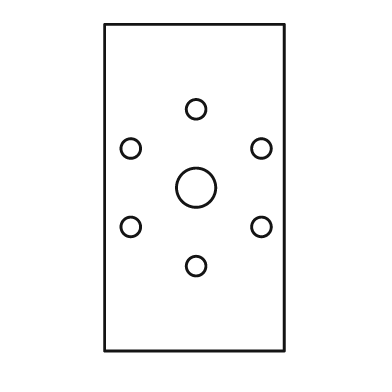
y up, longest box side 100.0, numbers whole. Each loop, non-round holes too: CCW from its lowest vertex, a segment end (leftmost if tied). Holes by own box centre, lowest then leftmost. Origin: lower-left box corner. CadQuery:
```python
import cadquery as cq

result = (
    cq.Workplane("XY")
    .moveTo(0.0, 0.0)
    .lineTo(55.0, 0.0)
    .lineTo(55.0, 100.0)
    .lineTo(0.0, 100.0)
    .close()
    .moveTo(28.0, 26.0)
    .circle(3.0)
    .moveTo(8.0, 38.0)
    .circle(3.0)
    .moveTo(48.0, 38.0)
    .circle(3.0)
    .moveTo(28.0, 50.0)
    .circle(6.0)
    .moveTo(8.0, 62.0)
    .circle(3.0)
    .moveTo(48.0, 62.0)
    .circle(3.0)
    .moveTo(28.0, 74.0)
    .circle(3.0)
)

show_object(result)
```